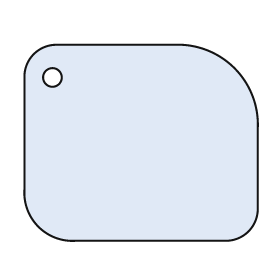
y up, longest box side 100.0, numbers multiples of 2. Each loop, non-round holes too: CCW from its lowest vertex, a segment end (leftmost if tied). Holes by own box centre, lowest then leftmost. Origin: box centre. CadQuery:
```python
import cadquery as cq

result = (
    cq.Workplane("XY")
    .moveTo(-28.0, -42.0)
    .lineTo(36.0, -42.0)
    .threePointArc((46.0, -38.0), (50.0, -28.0))
    .lineTo(50.0, 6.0)
    .threePointArc((40.0, 32.0), (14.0, 42.0))
    .lineTo(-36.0, 42.0)
    .threePointArc((-46.0, 38.0), (-50.0, 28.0))
    .lineTo(-50.0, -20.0)
    .threePointArc((-44.0, -36.0), (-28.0, -42.0))
    .close()
    .moveTo(-38.0, 28.0)
    .circle(4.0)
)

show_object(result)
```